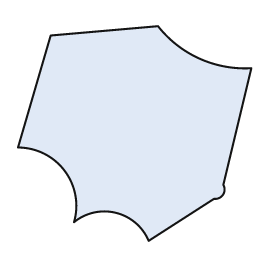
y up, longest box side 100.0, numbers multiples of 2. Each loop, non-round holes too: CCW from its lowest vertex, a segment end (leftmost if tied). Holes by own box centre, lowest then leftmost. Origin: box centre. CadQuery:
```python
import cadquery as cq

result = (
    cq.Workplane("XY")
    .moveTo(6.0, -46.0)
    .lineTo(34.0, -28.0)
    .threePointArc((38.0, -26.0), (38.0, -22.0))
    .lineTo(50.0, 28.0)
    .threePointArc((28.0, 32.0), (10.0, 46.0))
    .lineTo(-36.0, 42.0)
    .lineTo(-50.0, -6.0)
    .threePointArc((-30.0, -16.0), (-26.0, -38.0))
    .threePointArc((-8.0, -34.0), (6.0, -46.0))
    .close()
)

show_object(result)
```